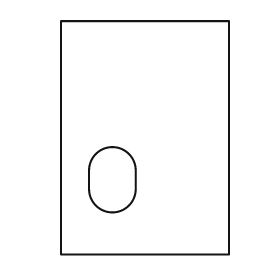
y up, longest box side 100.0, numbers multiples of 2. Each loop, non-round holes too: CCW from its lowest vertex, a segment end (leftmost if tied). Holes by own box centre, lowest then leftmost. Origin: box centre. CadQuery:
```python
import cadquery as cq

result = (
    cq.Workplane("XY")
    .moveTo(-36.0, -50.0)
    .lineTo(36.0, -50.0)
    .lineTo(36.0, 50.0)
    .lineTo(-36.0, 50.0)
    .close()
    .moveTo(-24.0, -22.0)
    .threePointArc((-14.0, -32.0), (-4.0, -22.0))
    .lineTo(-4.0, -14.0)
    .threePointArc((-14.0, -4.0), (-24.0, -14.0))
    .close()
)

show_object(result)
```